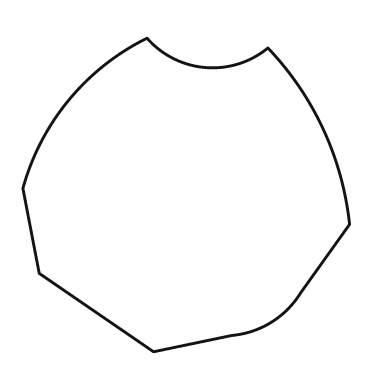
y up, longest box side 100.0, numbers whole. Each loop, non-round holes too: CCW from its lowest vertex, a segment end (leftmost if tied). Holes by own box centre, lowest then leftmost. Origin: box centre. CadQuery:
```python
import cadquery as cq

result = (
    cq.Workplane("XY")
    .moveTo(-10.0, -48.0)
    .lineTo(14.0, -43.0)
    .threePointArc((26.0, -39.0), (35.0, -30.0))
    .lineTo(50.0, -9.0)
    .threePointArc((42.0, 20.0), (25.0, 45.0))
    .threePointArc((6.0, 39.0), (-12.0, 48.0))
    .threePointArc((-36.0, 29.0), (-50.0, 2.0))
    .lineTo(-45.0, -24.0)
    .close()
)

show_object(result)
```